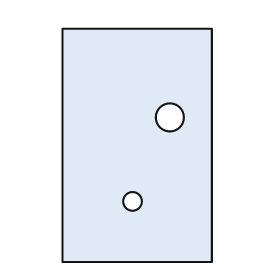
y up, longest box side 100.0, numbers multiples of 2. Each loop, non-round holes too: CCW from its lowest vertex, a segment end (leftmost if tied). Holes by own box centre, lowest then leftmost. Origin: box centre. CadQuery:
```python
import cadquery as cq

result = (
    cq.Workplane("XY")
    .moveTo(-32.0, -50.0)
    .lineTo(32.0, -50.0)
    .lineTo(32.0, 50.0)
    .lineTo(-32.0, 50.0)
    .close()
    .moveTo(-2.0, -24.0)
    .circle(4.0)
    .moveTo(14.0, 12.0)
    .circle(6.0)
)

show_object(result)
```